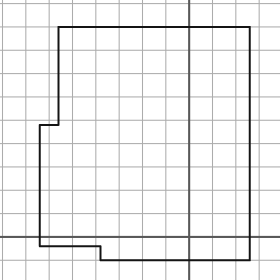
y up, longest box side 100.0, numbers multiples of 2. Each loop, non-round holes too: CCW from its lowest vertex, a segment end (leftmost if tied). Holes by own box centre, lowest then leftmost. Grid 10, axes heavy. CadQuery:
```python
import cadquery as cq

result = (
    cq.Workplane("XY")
    .moveTo(-38.0, -10.0)
    .lineTo(26.0, -10.0)
    .lineTo(26.0, 90.0)
    .lineTo(-56.0, 90.0)
    .lineTo(-56.0, 48.0)
    .lineTo(-64.0, 48.0)
    .lineTo(-64.0, -4.0)
    .lineTo(-38.0, -4.0)
    .close()
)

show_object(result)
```